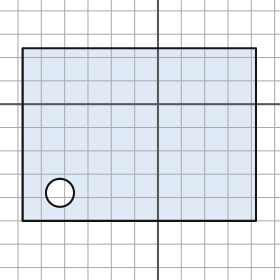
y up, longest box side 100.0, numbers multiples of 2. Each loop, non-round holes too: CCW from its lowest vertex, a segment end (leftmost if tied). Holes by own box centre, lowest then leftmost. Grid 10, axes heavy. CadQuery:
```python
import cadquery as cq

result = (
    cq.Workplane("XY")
    .moveTo(-58.0, -50.0)
    .lineTo(42.0, -50.0)
    .lineTo(42.0, 24.0)
    .lineTo(-58.0, 24.0)
    .close()
    .moveTo(-42.0, -38.0)
    .circle(6.0)
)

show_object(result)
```